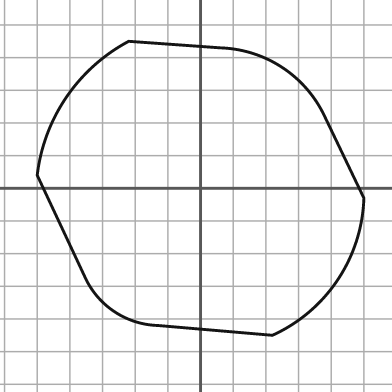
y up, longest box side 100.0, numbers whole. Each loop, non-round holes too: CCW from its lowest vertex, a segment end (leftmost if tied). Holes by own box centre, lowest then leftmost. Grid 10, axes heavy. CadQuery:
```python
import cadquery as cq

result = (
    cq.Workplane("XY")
    .moveTo(22.0, -45.0)
    .threePointArc((42.0, -28.0), (50.0, -3.0))
    .lineTo(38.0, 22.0)
    .threePointArc((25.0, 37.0), (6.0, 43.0))
    .lineTo(-22.0, 45.0)
    .threePointArc((-41.0, 28.0), (-50.0, 4.0))
    .lineTo(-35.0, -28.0)
    .threePointArc((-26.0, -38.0), (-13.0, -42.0))
    .close()
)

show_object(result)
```